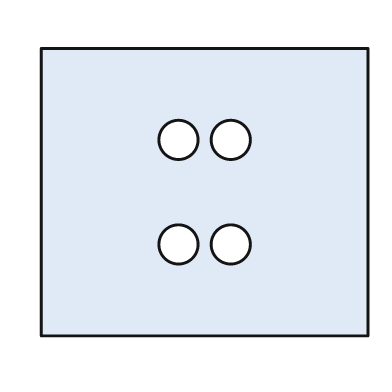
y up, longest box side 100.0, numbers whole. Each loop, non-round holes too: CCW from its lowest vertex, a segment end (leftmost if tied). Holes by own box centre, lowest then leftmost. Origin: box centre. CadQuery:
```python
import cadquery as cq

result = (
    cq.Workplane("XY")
    .moveTo(-50.0, -44.0)
    .lineTo(50.0, -44.0)
    .lineTo(50.0, 44.0)
    .lineTo(-50.0, 44.0)
    .close()
    .moveTo(-8.0, -16.0)
    .circle(6.0)
    .moveTo(8.0, -16.0)
    .circle(6.0)
    .moveTo(-8.0, 16.0)
    .circle(6.0)
    .moveTo(8.0, 16.0)
    .circle(6.0)
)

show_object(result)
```